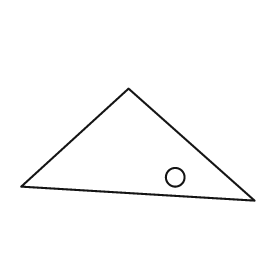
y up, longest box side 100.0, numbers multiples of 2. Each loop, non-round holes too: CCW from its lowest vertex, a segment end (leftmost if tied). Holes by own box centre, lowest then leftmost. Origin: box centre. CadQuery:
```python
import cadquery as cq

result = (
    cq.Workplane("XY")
    .moveTo(50.0, -24.0)
    .lineTo(-4.0, 24.0)
    .lineTo(-50.0, -18.0)
    .close()
    .moveTo(16.0, -14.0)
    .circle(4.0)
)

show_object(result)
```